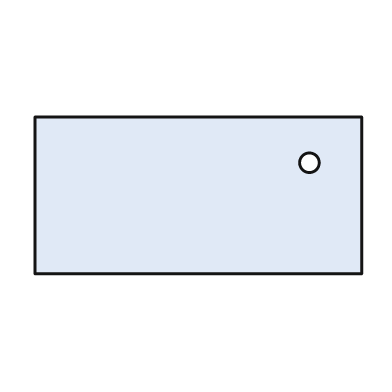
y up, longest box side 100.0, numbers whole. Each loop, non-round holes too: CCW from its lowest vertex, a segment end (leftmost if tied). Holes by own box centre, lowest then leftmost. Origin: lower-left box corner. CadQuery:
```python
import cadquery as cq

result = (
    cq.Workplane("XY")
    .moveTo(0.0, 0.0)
    .lineTo(100.0, 0.0)
    .lineTo(100.0, 48.0)
    .lineTo(0.0, 48.0)
    .close()
    .moveTo(84.0, 34.0)
    .circle(3.0)
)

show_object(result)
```